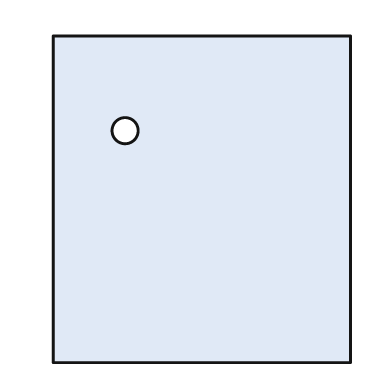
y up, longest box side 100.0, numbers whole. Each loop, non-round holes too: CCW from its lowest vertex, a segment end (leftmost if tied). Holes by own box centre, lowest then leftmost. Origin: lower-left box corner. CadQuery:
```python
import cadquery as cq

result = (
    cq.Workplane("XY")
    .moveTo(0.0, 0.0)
    .lineTo(91.0, 0.0)
    .lineTo(91.0, 100.0)
    .lineTo(0.0, 100.0)
    .close()
    .moveTo(22.0, 71.0)
    .circle(4.0)
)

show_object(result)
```